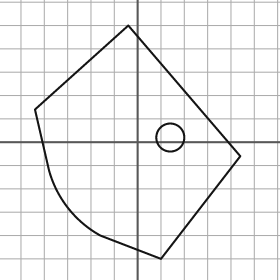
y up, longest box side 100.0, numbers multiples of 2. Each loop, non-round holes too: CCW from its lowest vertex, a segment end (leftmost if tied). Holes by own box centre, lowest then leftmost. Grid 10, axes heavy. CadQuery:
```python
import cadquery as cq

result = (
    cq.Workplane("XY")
    .moveTo(10.0, -50.0)
    .lineTo(44.0, -6.0)
    .lineTo(-4.0, 50.0)
    .lineTo(-44.0, 14.0)
    .lineTo(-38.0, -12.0)
    .threePointArc((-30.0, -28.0), (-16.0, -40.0))
    .close()
    .moveTo(14.0, 2.0)
    .circle(6.0)
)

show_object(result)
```